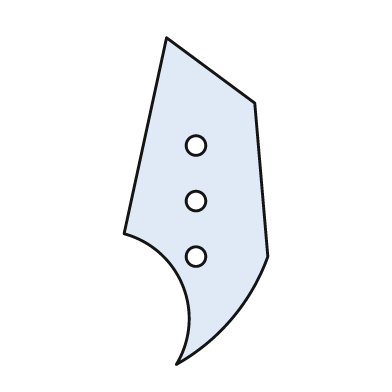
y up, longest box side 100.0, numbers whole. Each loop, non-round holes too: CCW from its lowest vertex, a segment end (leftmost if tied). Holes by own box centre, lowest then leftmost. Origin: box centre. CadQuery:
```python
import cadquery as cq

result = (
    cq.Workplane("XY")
    .moveTo(-6.0, -50.0)
    .threePointArc((11.0, -36.0), (22.0, -17.0))
    .lineTo(18.0, 30.0)
    .lineTo(-9.0, 50.0)
    .lineTo(-22.0, -10.0)
    .threePointArc((-4.0, -26.0), (-6.0, -50.0))
    .close()
    .moveTo(0.0, -17.0)
    .circle(3.0)
    .moveTo(0.0, 0.0)
    .circle(3.0)
    .moveTo(0.0, 17.0)
    .circle(3.0)
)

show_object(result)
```